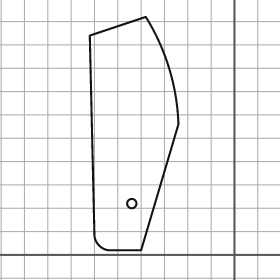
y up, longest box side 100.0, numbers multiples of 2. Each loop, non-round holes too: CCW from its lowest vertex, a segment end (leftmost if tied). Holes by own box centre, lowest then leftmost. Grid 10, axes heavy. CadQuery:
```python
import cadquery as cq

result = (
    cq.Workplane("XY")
    .moveTo(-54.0, 2.0)
    .lineTo(-40.0, 2.0)
    .lineTo(-24.0, 56.0)
    .threePointArc((-28.0, 80.0), (-38.0, 102.0))
    .lineTo(-62.0, 94.0)
    .lineTo(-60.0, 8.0)
    .threePointArc((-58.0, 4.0), (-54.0, 2.0))
    .close()
    .moveTo(-44.0, 22.0)
    .circle(2.0)
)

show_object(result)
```